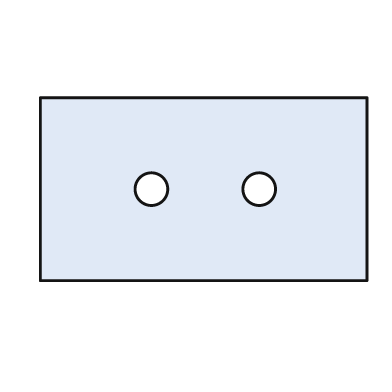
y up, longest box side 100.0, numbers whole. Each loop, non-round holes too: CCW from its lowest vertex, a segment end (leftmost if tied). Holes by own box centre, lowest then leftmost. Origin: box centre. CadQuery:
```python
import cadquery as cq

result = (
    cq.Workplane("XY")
    .moveTo(-50.0, -28.0)
    .lineTo(50.0, -28.0)
    .lineTo(50.0, 28.0)
    .lineTo(-50.0, 28.0)
    .close()
    .moveTo(-16.0, 0.0)
    .circle(5.0)
    .moveTo(17.0, 0.0)
    .circle(5.0)
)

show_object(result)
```